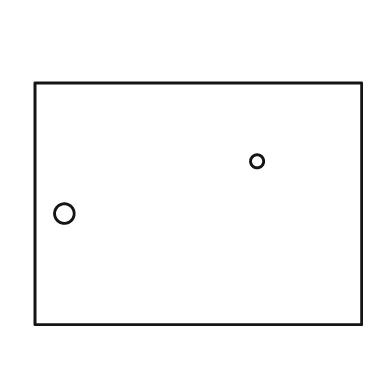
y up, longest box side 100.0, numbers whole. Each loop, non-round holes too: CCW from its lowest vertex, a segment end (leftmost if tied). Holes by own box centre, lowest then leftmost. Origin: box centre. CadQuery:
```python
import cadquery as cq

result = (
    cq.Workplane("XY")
    .moveTo(-50.0, -37.0)
    .lineTo(50.0, -37.0)
    .lineTo(50.0, 37.0)
    .lineTo(-50.0, 37.0)
    .close()
    .moveTo(-41.0, -3.0)
    .circle(3.0)
    .moveTo(18.0, 13.0)
    .circle(2.0)
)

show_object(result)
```